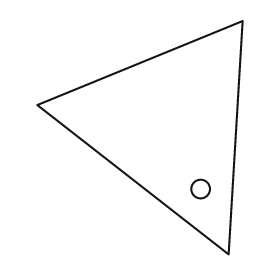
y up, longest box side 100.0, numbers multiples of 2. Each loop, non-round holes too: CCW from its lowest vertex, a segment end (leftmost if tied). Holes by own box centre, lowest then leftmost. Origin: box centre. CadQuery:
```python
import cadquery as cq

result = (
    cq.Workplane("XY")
    .moveTo(38.0, -50.0)
    .lineTo(44.0, 50.0)
    .lineTo(-44.0, 14.0)
    .close()
    .moveTo(26.0, -22.0)
    .circle(4.0)
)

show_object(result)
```